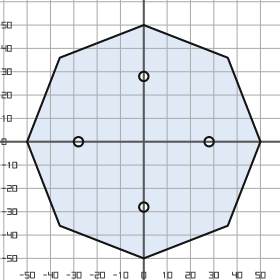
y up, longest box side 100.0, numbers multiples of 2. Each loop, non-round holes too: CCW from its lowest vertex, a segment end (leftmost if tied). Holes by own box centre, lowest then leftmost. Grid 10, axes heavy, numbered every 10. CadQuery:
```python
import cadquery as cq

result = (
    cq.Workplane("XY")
    .moveTo(0.0, -50.0)
    .lineTo(36.0, -36.0)
    .lineTo(50.0, 0.0)
    .lineTo(36.0, 36.0)
    .lineTo(0.0, 50.0)
    .lineTo(-36.0, 36.0)
    .lineTo(-50.0, 0.0)
    .lineTo(-36.0, -36.0)
    .close()
    .moveTo(0.0, -28.0)
    .circle(2.0)
    .moveTo(-28.0, 0.0)
    .circle(2.0)
    .moveTo(28.0, 0.0)
    .circle(2.0)
    .moveTo(0.0, 28.0)
    .circle(2.0)
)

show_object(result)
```